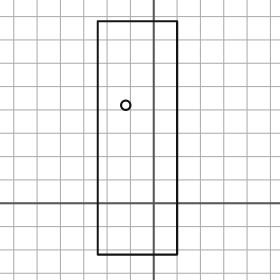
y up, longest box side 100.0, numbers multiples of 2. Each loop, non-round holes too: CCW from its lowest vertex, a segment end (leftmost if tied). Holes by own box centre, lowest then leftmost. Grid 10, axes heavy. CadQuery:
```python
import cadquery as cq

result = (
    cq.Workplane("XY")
    .moveTo(-24.0, -22.0)
    .lineTo(10.0, -22.0)
    .lineTo(10.0, 78.0)
    .lineTo(-24.0, 78.0)
    .close()
    .moveTo(-12.0, 42.0)
    .circle(2.0)
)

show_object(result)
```